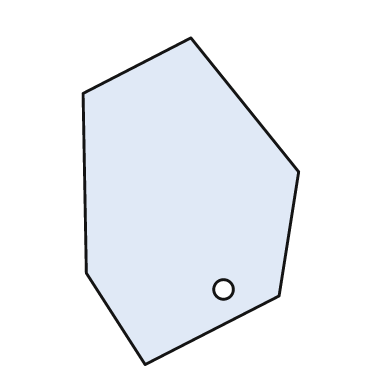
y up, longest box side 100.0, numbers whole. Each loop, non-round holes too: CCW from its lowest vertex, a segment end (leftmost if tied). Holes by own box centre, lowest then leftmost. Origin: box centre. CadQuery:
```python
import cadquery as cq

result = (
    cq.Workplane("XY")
    .moveTo(-14.0, -50.0)
    .lineTo(27.0, -29.0)
    .lineTo(33.0, 9.0)
    .lineTo(0.0, 50.0)
    .lineTo(-33.0, 33.0)
    .lineTo(-32.0, -22.0)
    .close()
    .moveTo(10.0, -27.0)
    .circle(3.0)
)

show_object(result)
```